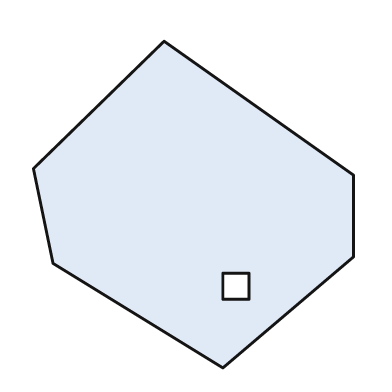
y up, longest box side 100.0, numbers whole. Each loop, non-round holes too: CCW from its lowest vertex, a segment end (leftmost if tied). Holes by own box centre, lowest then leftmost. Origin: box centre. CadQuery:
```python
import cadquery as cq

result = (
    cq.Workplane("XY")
    .moveTo(9.0, -50.0)
    .lineTo(49.0, -16.0)
    .lineTo(49.0, 9.0)
    .lineTo(-9.0, 50.0)
    .lineTo(-49.0, 11.0)
    .lineTo(-43.0, -18.0)
    .close()
    .moveTo(9.0, -29.0)
    .lineTo(17.0, -29.0)
    .lineTo(17.0, -21.0)
    .lineTo(9.0, -21.0)
    .close()
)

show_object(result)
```